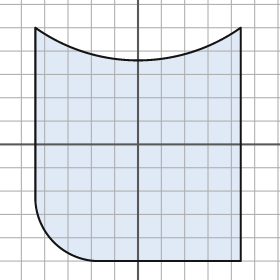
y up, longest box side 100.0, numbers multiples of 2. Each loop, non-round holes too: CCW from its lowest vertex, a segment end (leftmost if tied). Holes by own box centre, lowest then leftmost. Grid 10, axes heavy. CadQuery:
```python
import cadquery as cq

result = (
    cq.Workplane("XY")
    .moveTo(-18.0, -50.0)
    .lineTo(44.0, -50.0)
    .lineTo(44.0, 50.0)
    .threePointArc((0.0, 36.0), (-44.0, 50.0))
    .lineTo(-44.0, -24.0)
    .threePointArc((-36.0, -42.0), (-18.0, -50.0))
    .close()
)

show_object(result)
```